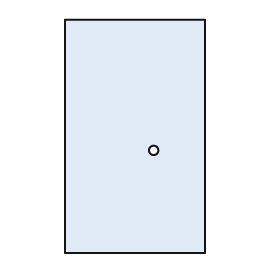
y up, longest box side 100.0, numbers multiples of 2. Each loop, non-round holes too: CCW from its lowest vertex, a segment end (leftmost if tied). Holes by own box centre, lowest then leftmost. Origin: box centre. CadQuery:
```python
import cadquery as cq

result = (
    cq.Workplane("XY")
    .moveTo(-30.0, -50.0)
    .lineTo(30.0, -50.0)
    .lineTo(30.0, 50.0)
    .lineTo(-30.0, 50.0)
    .close()
    .moveTo(8.0, -6.0)
    .circle(2.0)
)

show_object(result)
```